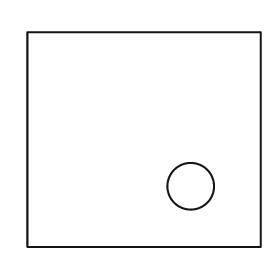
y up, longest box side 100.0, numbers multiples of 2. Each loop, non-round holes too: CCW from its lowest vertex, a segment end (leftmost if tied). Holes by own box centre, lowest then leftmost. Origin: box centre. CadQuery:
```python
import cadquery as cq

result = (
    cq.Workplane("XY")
    .moveTo(-50.0, -46.0)
    .lineTo(50.0, -46.0)
    .lineTo(50.0, 46.0)
    .lineTo(-50.0, 46.0)
    .close()
    .moveTo(20.0, -20.0)
    .circle(10.0)
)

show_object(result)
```